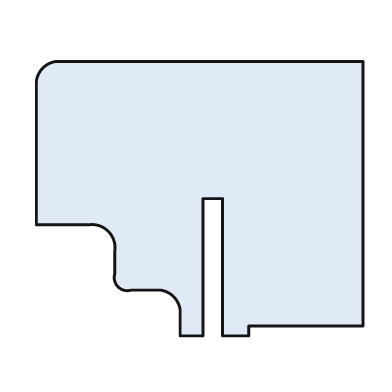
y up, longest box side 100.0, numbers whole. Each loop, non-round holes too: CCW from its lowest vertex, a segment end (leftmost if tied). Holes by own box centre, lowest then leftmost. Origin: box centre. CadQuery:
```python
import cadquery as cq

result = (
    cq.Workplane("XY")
    .moveTo(-6.0, -42.0)
    .lineTo(1.0, -42.0)
    .lineTo(1.0, 0.0)
    .lineTo(7.0, 0.0)
    .lineTo(7.0, -42.0)
    .lineTo(15.0, -42.0)
    .lineTo(15.0, -39.0)
    .lineTo(50.0, -39.0)
    .lineTo(50.0, 42.0)
    .lineTo(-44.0, 42.0)
    .threePointArc((-48.0, 40.0), (-50.0, 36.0))
    .lineTo(-50.0, -8.0)
    .lineTo(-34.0, -8.0)
    .threePointArc((-28.0, -10.0), (-26.0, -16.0))
    .lineTo(-26.0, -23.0)
    .threePointArc((-25.0, -27.0), (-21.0, -28.0))
    .lineTo(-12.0, -28.0)
    .threePointArc((-8.0, -30.0), (-6.0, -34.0))
    .close()
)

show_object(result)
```